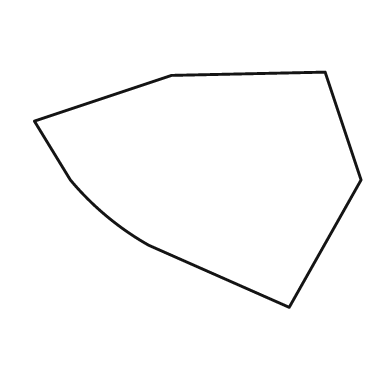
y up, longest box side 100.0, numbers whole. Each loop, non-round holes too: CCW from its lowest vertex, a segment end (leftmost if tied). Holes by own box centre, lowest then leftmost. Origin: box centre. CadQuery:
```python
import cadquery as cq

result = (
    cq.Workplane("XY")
    .moveTo(28.0, -36.0)
    .lineTo(50.0, 3.0)
    .lineTo(39.0, 36.0)
    .lineTo(-8.0, 35.0)
    .lineTo(-50.0, 21.0)
    .lineTo(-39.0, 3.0)
    .threePointArc((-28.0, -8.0), (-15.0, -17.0))
    .close()
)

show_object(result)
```